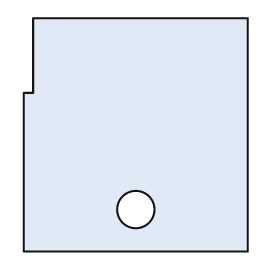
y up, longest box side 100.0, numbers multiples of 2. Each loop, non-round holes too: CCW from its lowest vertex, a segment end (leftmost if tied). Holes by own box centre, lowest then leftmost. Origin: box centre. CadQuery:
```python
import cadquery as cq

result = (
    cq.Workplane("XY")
    .moveTo(-48.0, -50.0)
    .lineTo(48.0, -50.0)
    .lineTo(48.0, 50.0)
    .lineTo(-44.0, 50.0)
    .lineTo(-44.0, 18.0)
    .lineTo(-48.0, 18.0)
    .close()
    .moveTo(0.0, -32.0)
    .circle(8.0)
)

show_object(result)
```